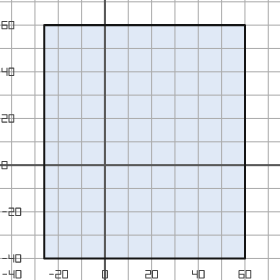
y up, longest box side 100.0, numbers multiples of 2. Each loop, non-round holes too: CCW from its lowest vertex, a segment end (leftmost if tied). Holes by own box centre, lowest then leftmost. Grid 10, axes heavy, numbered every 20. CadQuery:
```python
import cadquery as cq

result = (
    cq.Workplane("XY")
    .moveTo(-26.0, -40.0)
    .lineTo(60.0, -40.0)
    .lineTo(60.0, 60.0)
    .lineTo(-26.0, 60.0)
    .close()
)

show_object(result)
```